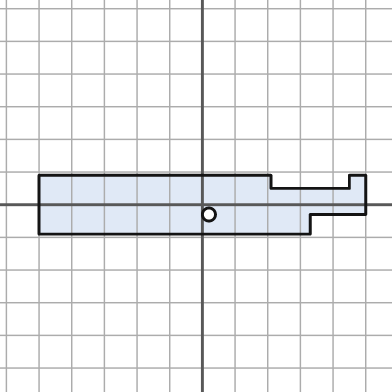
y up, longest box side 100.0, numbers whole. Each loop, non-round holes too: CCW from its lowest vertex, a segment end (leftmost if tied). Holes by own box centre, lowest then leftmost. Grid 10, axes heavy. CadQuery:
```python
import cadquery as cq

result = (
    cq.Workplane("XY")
    .moveTo(-50.0, -9.0)
    .lineTo(33.0, -9.0)
    .lineTo(33.0, -3.0)
    .lineTo(50.0, -3.0)
    .lineTo(50.0, 9.0)
    .lineTo(45.0, 9.0)
    .lineTo(45.0, 5.0)
    .lineTo(21.0, 5.0)
    .lineTo(21.0, 9.0)
    .lineTo(-50.0, 9.0)
    .close()
    .moveTo(2.0, -3.0)
    .circle(2.0)
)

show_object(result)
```